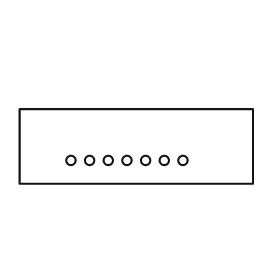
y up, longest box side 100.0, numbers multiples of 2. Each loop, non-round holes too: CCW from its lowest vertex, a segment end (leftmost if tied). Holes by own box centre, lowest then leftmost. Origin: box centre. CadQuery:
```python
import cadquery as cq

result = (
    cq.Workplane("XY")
    .moveTo(-50.0, -16.0)
    .lineTo(50.0, -16.0)
    .lineTo(50.0, 16.0)
    .lineTo(-50.0, 16.0)
    .close()
    .moveTo(-28.0, -6.0)
    .circle(2.0)
    .moveTo(-20.0, -6.0)
    .circle(2.0)
    .moveTo(-12.0, -6.0)
    .circle(2.0)
    .moveTo(-4.0, -6.0)
    .circle(2.0)
    .moveTo(4.0, -6.0)
    .circle(2.0)
    .moveTo(12.0, -6.0)
    .circle(2.0)
    .moveTo(20.0, -6.0)
    .circle(2.0)
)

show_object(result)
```